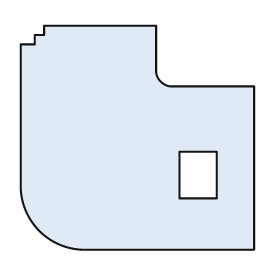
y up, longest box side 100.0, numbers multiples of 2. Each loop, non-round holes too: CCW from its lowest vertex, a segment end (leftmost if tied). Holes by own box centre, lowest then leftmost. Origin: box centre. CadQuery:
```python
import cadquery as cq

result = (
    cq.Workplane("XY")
    .moveTo(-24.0, -48.0)
    .lineTo(50.0, -48.0)
    .lineTo(50.0, 22.0)
    .lineTo(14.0, 22.0)
    .threePointArc((10.0, 24.0), (8.0, 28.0))
    .lineTo(8.0, 48.0)
    .lineTo(-40.0, 48.0)
    .lineTo(-40.0, 44.0)
    .lineTo(-44.0, 44.0)
    .lineTo(-44.0, 40.0)
    .lineTo(-50.0, 40.0)
    .lineTo(-50.0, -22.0)
    .threePointArc((-42.0, -40.0), (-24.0, -48.0))
    .close()
    .moveTo(18.0, -26.0)
    .lineTo(34.0, -26.0)
    .lineTo(34.0, -6.0)
    .lineTo(18.0, -6.0)
    .close()
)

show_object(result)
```